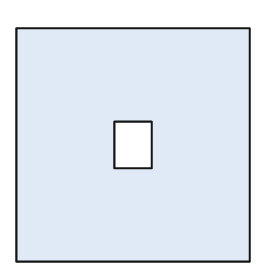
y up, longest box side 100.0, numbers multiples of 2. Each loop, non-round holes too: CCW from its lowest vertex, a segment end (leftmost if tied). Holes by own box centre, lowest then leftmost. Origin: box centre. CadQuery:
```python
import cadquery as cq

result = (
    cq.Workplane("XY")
    .moveTo(-50.0, -50.0)
    .lineTo(50.0, -50.0)
    .lineTo(50.0, 50.0)
    .lineTo(-50.0, 50.0)
    .close()
    .moveTo(-8.0, -10.0)
    .lineTo(8.0, -10.0)
    .lineTo(8.0, 10.0)
    .lineTo(-8.0, 10.0)
    .close()
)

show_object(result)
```